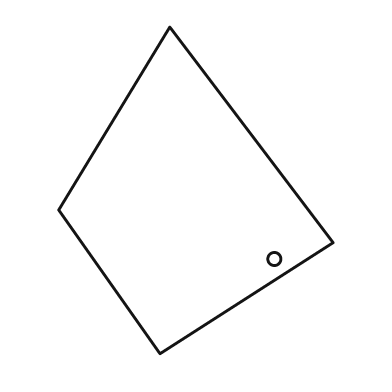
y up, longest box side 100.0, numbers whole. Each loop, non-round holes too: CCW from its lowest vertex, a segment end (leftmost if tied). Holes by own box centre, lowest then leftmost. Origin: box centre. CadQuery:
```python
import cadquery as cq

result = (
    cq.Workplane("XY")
    .moveTo(-11.0, -50.0)
    .lineTo(42.0, -16.0)
    .lineTo(-8.0, 50.0)
    .lineTo(-42.0, -6.0)
    .close()
    .moveTo(24.0, -21.0)
    .circle(2.0)
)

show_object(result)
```